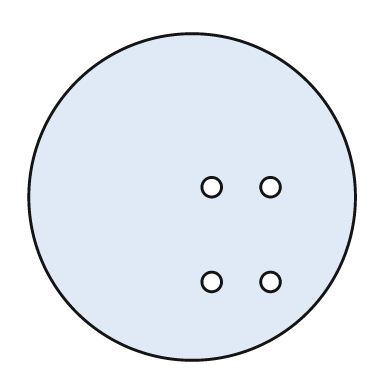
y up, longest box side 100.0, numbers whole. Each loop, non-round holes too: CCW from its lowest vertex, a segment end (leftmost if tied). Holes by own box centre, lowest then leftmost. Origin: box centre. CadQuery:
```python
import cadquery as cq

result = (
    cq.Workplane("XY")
    .moveTo(0.0, 0.0)
    .circle(50.0)
    .moveTo(6.0, -26.0)
    .circle(3.0)
    .moveTo(24.0, -26.0)
    .circle(3.0)
    .moveTo(6.0, 3.0)
    .circle(3.0)
    .moveTo(24.0, 3.0)
    .circle(3.0)
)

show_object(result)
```